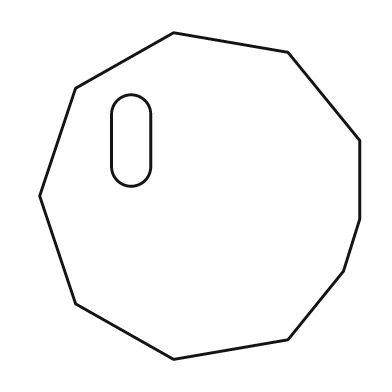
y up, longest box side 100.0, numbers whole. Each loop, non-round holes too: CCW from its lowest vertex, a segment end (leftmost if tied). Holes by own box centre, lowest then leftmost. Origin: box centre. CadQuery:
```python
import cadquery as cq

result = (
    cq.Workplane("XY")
    .moveTo(-8.0, -50.0)
    .lineTo(27.0, -44.0)
    .lineTo(44.0, -23.0)
    .lineTo(49.0, -7.0)
    .lineTo(49.0, 17.0)
    .lineTo(27.0, 44.0)
    .lineTo(-8.0, 50.0)
    .lineTo(-38.0, 33.0)
    .lineTo(-49.0, 0.0)
    .lineTo(-38.0, -33.0)
    .close()
    .moveTo(-27.0, 9.0)
    .threePointArc((-21.0, 3.0), (-15.0, 9.0))
    .lineTo(-15.0, 25.0)
    .threePointArc((-21.0, 31.0), (-27.0, 25.0))
    .close()
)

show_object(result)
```